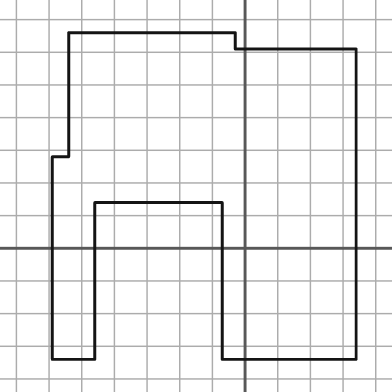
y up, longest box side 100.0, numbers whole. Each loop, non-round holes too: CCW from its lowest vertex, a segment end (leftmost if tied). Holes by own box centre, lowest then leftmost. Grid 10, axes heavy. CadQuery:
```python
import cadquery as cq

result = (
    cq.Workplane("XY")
    .moveTo(-59.0, -34.0)
    .lineTo(-46.0, -34.0)
    .lineTo(-46.0, 14.0)
    .lineTo(-7.0, 14.0)
    .lineTo(-7.0, -34.0)
    .lineTo(34.0, -34.0)
    .lineTo(34.0, 61.0)
    .lineTo(-3.0, 61.0)
    .lineTo(-3.0, 66.0)
    .lineTo(-54.0, 66.0)
    .lineTo(-54.0, 28.0)
    .lineTo(-59.0, 28.0)
    .close()
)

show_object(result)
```